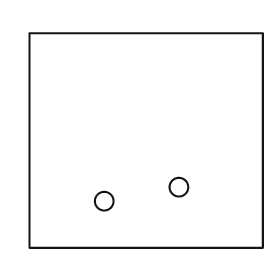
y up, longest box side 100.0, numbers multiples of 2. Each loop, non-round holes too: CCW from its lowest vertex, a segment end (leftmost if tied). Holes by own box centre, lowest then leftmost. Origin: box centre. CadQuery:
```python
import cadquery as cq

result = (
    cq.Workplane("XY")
    .moveTo(-50.0, -46.0)
    .lineTo(50.0, -46.0)
    .lineTo(50.0, 46.0)
    .lineTo(-50.0, 46.0)
    .close()
    .moveTo(-18.0, -26.0)
    .circle(4.0)
    .moveTo(14.0, -20.0)
    .circle(4.0)
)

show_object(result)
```